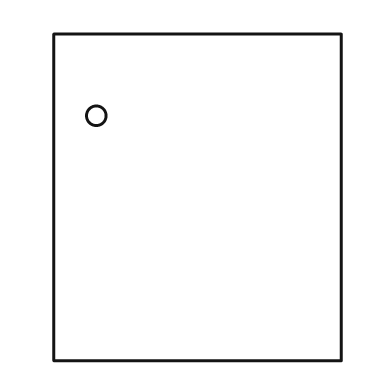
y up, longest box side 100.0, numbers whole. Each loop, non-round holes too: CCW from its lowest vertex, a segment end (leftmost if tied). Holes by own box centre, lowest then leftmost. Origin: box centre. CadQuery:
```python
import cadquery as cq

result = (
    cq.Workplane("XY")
    .moveTo(-44.0, -50.0)
    .lineTo(44.0, -50.0)
    .lineTo(44.0, 50.0)
    .lineTo(-44.0, 50.0)
    .close()
    .moveTo(-31.0, 25.0)
    .circle(3.0)
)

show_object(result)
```